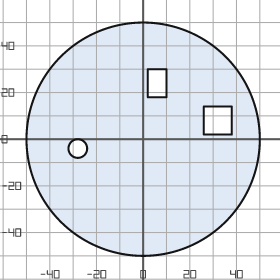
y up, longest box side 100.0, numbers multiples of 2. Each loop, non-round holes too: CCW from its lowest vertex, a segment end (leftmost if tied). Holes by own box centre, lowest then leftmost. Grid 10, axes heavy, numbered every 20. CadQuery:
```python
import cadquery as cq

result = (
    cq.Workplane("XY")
    .moveTo(0.0, 0.0)
    .circle(50.0)
    .moveTo(-28.0, -4.0)
    .circle(4.0)
    .moveTo(26.0, 2.0)
    .lineTo(38.0, 2.0)
    .lineTo(38.0, 14.0)
    .lineTo(26.0, 14.0)
    .close()
    .moveTo(2.0, 18.0)
    .lineTo(10.0, 18.0)
    .lineTo(10.0, 30.0)
    .lineTo(2.0, 30.0)
    .close()
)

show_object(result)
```